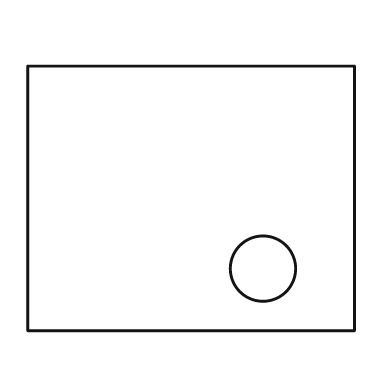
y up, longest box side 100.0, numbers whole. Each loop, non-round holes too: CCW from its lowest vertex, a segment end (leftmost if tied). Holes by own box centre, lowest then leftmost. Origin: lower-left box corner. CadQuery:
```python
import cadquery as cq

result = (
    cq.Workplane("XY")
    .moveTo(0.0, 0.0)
    .lineTo(100.0, 0.0)
    .lineTo(100.0, 81.0)
    .lineTo(0.0, 81.0)
    .close()
    .moveTo(72.0, 19.0)
    .circle(10.0)
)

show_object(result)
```